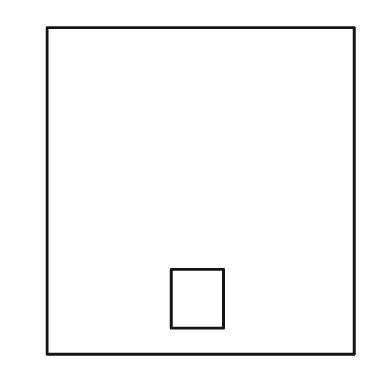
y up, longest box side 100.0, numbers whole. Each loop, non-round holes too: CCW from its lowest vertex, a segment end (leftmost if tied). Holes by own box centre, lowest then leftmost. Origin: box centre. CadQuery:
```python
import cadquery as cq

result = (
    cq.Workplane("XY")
    .moveTo(-47.0, -50.0)
    .lineTo(47.0, -50.0)
    .lineTo(47.0, 50.0)
    .lineTo(-47.0, 50.0)
    .close()
    .moveTo(-9.0, -42.0)
    .lineTo(7.0, -42.0)
    .lineTo(7.0, -24.0)
    .lineTo(-9.0, -24.0)
    .close()
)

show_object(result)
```